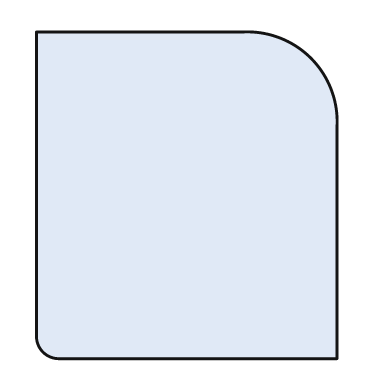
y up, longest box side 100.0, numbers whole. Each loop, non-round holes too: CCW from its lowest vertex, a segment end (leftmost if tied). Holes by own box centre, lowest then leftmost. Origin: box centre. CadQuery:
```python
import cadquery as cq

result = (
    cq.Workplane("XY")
    .moveTo(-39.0, -50.0)
    .lineTo(46.0, -50.0)
    .lineTo(46.0, 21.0)
    .threePointArc((38.0, 42.0), (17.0, 50.0))
    .lineTo(-46.0, 50.0)
    .lineTo(-46.0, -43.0)
    .threePointArc((-44.0, -48.0), (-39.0, -50.0))
    .close()
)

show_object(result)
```